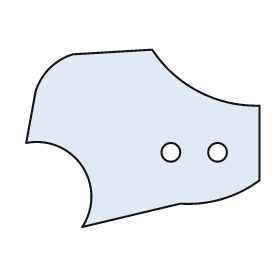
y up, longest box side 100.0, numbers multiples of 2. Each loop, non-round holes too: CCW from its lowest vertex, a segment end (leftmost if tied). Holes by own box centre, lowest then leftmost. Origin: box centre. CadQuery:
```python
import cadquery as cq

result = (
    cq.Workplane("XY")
    .moveTo(-26.0, -38.0)
    .lineTo(16.0, -28.0)
    .threePointArc((34.0, -26.0), (50.0, -18.0))
    .lineTo(50.0, 14.0)
    .threePointArc((24.0, 20.0), (4.0, 38.0))
    .lineTo(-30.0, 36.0)
    .threePointArc((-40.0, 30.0), (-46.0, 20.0))
    .lineTo(-50.0, -2.0)
    .threePointArc((-26.0, -12.0), (-26.0, -38.0))
    .close()
    .moveTo(12.0, -6.0)
    .circle(4.0)
    .moveTo(32.0, -6.0)
    .circle(4.0)
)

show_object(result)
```